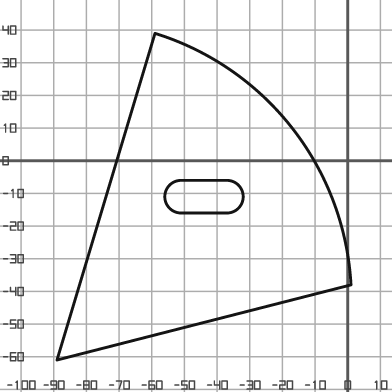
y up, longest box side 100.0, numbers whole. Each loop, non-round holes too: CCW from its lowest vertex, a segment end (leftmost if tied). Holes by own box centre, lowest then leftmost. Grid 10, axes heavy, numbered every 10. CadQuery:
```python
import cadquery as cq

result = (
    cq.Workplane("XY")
    .moveTo(-89.0, -61.0)
    .lineTo(1.0, -38.0)
    .threePointArc((-17.0, 10.0), (-59.0, 39.0))
    .close()
    .moveTo(-51.0, -16.0)
    .lineTo(-37.0, -16.0)
    .threePointArc((-32.0, -11.0), (-37.0, -6.0))
    .lineTo(-51.0, -6.0)
    .threePointArc((-56.0, -11.0), (-51.0, -16.0))
    .close()
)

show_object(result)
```